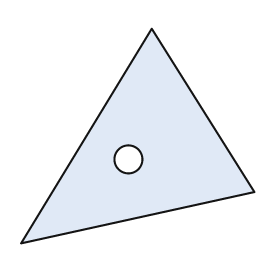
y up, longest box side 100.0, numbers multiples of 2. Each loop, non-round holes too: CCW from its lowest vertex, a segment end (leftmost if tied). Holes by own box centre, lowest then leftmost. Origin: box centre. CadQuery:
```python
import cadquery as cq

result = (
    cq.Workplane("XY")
    .moveTo(-50.0, -46.0)
    .lineTo(50.0, -24.0)
    .lineTo(6.0, 46.0)
    .close()
    .moveTo(-4.0, -10.0)
    .circle(6.0)
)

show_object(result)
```